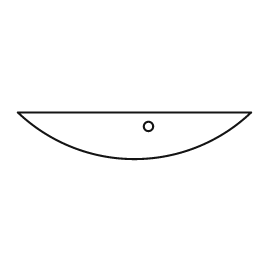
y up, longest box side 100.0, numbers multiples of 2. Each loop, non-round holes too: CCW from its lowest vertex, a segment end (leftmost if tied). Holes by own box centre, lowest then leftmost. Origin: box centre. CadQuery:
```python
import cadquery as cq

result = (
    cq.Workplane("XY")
    .moveTo(-50.0, 10.0)
    .threePointArc((0.0, -10.0), (50.0, 10.0))
    .close()
    .moveTo(6.0, 4.0)
    .circle(2.0)
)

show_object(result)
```